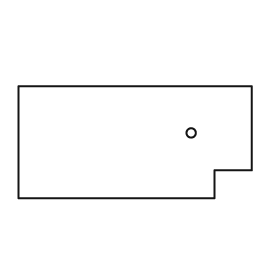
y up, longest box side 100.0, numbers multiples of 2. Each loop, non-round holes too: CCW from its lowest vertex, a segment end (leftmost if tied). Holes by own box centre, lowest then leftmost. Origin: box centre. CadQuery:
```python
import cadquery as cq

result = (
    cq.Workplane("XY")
    .moveTo(-50.0, -24.0)
    .lineTo(34.0, -24.0)
    .lineTo(34.0, -12.0)
    .lineTo(50.0, -12.0)
    .lineTo(50.0, 24.0)
    .lineTo(-50.0, 24.0)
    .close()
    .moveTo(24.0, 4.0)
    .circle(2.0)
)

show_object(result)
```